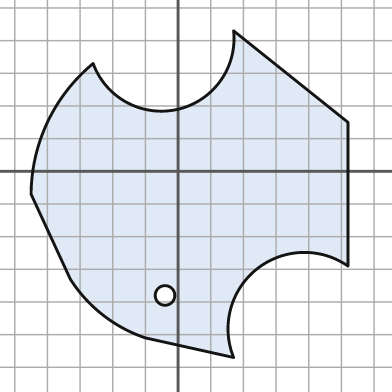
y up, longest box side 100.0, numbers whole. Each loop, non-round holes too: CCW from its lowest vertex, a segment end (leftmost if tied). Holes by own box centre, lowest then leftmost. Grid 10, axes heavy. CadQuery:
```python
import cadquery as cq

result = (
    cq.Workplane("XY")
    .moveTo(17.0, -57.0)
    .threePointArc((24.0, -30.0), (52.0, -29.0))
    .lineTo(52.0, 15.0)
    .lineTo(17.0, 43.0)
    .threePointArc((0.0, 19.0), (-26.0, 33.0))
    .threePointArc((-40.0, 15.0), (-45.0, -7.0))
    .lineTo(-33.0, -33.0)
    .threePointArc((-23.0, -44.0), (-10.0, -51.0))
    .close()
    .moveTo(-4.0, -38.0)
    .circle(3.0)
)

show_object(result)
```